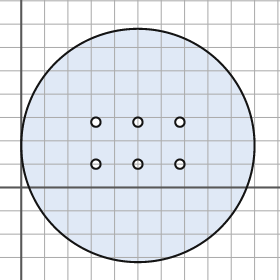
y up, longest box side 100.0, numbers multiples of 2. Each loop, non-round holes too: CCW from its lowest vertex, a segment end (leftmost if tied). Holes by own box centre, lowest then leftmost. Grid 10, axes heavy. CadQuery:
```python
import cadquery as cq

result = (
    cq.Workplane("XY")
    .moveTo(50.0, 18.0)
    .circle(50.0)
    .moveTo(32.0, 10.0)
    .circle(2.0)
    .moveTo(50.0, 10.0)
    .circle(2.0)
    .moveTo(68.0, 10.0)
    .circle(2.0)
    .moveTo(32.0, 28.0)
    .circle(2.0)
    .moveTo(50.0, 28.0)
    .circle(2.0)
    .moveTo(68.0, 28.0)
    .circle(2.0)
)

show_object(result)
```